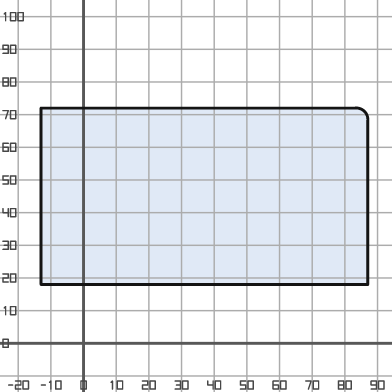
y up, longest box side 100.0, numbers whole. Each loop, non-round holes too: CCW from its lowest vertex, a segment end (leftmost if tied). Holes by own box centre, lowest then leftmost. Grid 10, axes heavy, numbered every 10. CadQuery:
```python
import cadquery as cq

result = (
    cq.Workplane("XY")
    .moveTo(-13.0, 18.0)
    .lineTo(87.0, 18.0)
    .lineTo(87.0, 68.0)
    .threePointArc((86.0, 71.0), (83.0, 72.0))
    .lineTo(-13.0, 72.0)
    .close()
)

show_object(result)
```